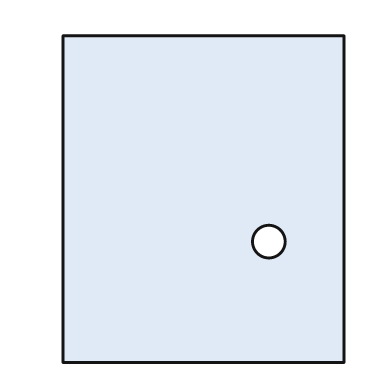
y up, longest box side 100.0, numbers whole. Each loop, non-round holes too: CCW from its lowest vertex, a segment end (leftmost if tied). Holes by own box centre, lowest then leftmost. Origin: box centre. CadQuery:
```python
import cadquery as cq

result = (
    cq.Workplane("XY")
    .moveTo(-43.0, -50.0)
    .lineTo(43.0, -50.0)
    .lineTo(43.0, 50.0)
    .lineTo(-43.0, 50.0)
    .close()
    .moveTo(20.0, -13.0)
    .circle(5.0)
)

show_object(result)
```